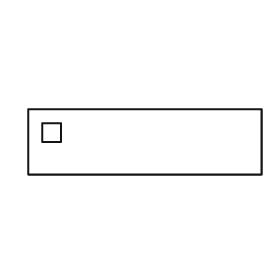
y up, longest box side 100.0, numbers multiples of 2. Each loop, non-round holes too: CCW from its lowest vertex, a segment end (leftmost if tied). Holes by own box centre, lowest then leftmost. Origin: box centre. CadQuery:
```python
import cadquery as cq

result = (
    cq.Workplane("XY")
    .moveTo(-50.0, -14.0)
    .lineTo(50.0, -14.0)
    .lineTo(50.0, 14.0)
    .lineTo(-50.0, 14.0)
    .close()
    .moveTo(-44.0, 0.0)
    .lineTo(-36.0, 0.0)
    .lineTo(-36.0, 8.0)
    .lineTo(-44.0, 8.0)
    .close()
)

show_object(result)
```